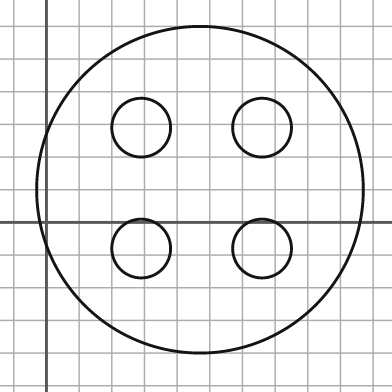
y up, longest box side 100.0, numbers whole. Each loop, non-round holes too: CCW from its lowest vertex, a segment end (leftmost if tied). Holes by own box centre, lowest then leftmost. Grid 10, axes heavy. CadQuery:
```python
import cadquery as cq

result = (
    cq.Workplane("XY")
    .moveTo(47.0, 10.0)
    .circle(50.0)
    .moveTo(29.0, -8.0)
    .circle(9.0)
    .moveTo(66.0, -8.0)
    .circle(9.0)
    .moveTo(29.0, 29.0)
    .circle(9.0)
    .moveTo(66.0, 29.0)
    .circle(9.0)
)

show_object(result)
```